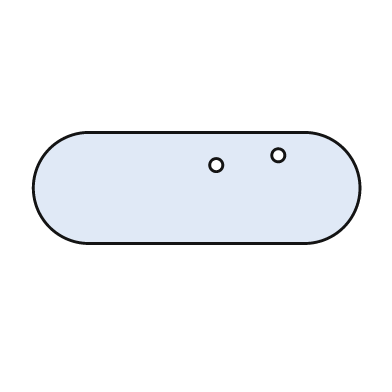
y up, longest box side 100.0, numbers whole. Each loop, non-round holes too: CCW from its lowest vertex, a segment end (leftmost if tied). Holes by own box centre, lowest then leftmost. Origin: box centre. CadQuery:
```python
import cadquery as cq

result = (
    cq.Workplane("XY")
    .moveTo(-33.0, -17.0)
    .lineTo(33.0, -17.0)
    .threePointArc((50.0, 0.0), (33.0, 17.0))
    .lineTo(-33.0, 17.0)
    .threePointArc((-50.0, 0.0), (-33.0, -17.0))
    .close()
    .moveTo(6.0, 7.0)
    .circle(2.0)
    .moveTo(25.0, 10.0)
    .circle(2.0)
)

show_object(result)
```